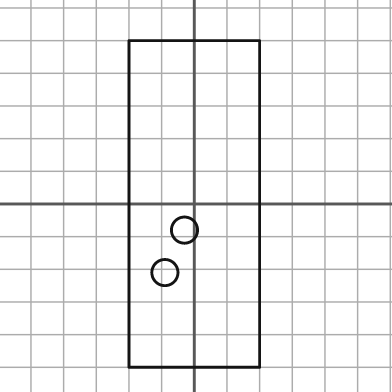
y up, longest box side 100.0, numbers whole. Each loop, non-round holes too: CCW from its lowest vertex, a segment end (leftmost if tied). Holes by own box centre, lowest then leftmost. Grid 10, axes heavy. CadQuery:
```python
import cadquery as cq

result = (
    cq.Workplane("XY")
    .moveTo(-20.0, -50.0)
    .lineTo(20.0, -50.0)
    .lineTo(20.0, 50.0)
    .lineTo(-20.0, 50.0)
    .close()
    .moveTo(-9.0, -21.0)
    .circle(4.0)
    .moveTo(-3.0, -8.0)
    .circle(4.0)
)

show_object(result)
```